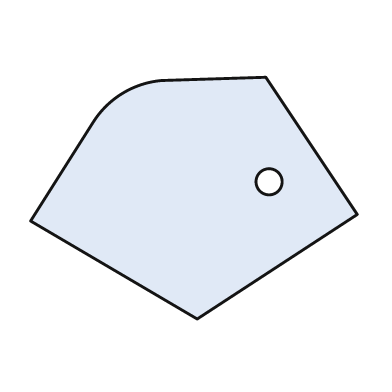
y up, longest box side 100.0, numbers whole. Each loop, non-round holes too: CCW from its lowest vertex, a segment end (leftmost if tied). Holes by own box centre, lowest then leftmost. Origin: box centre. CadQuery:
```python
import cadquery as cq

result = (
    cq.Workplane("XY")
    .moveTo(1.0, -37.0)
    .lineTo(50.0, -5.0)
    .lineTo(22.0, 37.0)
    .lineTo(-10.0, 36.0)
    .threePointArc((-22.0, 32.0), (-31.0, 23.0))
    .lineTo(-50.0, -7.0)
    .close()
    .moveTo(23.0, 5.0)
    .circle(4.0)
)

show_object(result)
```